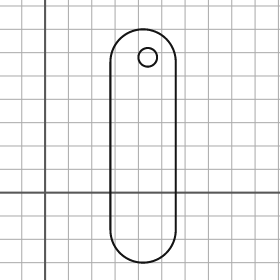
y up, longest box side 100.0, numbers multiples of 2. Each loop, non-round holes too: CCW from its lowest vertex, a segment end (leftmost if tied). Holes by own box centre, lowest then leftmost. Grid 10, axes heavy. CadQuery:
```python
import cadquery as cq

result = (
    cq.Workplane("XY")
    .moveTo(28.0, -16.0)
    .threePointArc((42.0, -30.0), (56.0, -16.0))
    .lineTo(56.0, 56.0)
    .threePointArc((42.0, 70.0), (28.0, 56.0))
    .close()
    .moveTo(44.0, 58.0)
    .circle(4.0)
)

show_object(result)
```